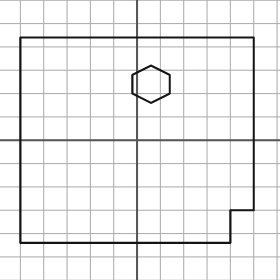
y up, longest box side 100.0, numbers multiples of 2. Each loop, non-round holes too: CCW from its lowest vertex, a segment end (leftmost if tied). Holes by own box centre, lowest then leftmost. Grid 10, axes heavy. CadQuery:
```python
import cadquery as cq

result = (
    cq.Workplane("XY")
    .moveTo(-50.0, -44.0)
    .lineTo(40.0, -44.0)
    .lineTo(40.0, -30.0)
    .lineTo(50.0, -30.0)
    .lineTo(50.0, 44.0)
    .lineTo(-50.0, 44.0)
    .close()
    .moveTo(6.0, 16.0)
    .lineTo(14.0, 20.0)
    .lineTo(14.0, 28.0)
    .lineTo(6.0, 32.0)
    .lineTo(-2.0, 28.0)
    .lineTo(-2.0, 20.0)
    .close()
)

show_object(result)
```